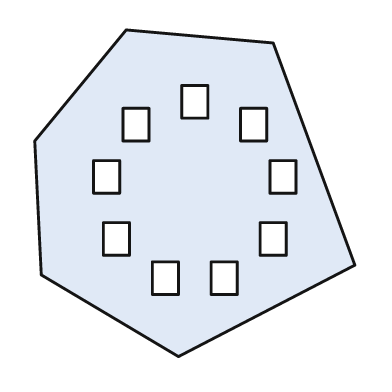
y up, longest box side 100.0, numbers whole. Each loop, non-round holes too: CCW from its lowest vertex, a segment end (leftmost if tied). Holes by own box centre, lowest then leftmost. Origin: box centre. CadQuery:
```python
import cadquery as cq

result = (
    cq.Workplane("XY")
    .moveTo(-5.0, -50.0)
    .lineTo(49.0, -22.0)
    .lineTo(24.0, 46.0)
    .lineTo(-21.0, 50.0)
    .lineTo(-49.0, 16.0)
    .lineTo(-47.0, -25.0)
    .close()
    .moveTo(-13.0, -31.0)
    .lineTo(-5.0, -31.0)
    .lineTo(-5.0, -21.0)
    .lineTo(-13.0, -21.0)
    .close()
    .moveTo(5.0, -31.0)
    .lineTo(13.0, -31.0)
    .lineTo(13.0, -21.0)
    .lineTo(5.0, -21.0)
    .close()
    .moveTo(-28.0, -19.0)
    .lineTo(-20.0, -19.0)
    .lineTo(-20.0, -9.0)
    .lineTo(-28.0, -9.0)
    .close()
    .moveTo(20.0, -19.0)
    .lineTo(28.0, -19.0)
    .lineTo(28.0, -9.0)
    .lineTo(20.0, -9.0)
    .close()
    .moveTo(-31.0, 0.0)
    .lineTo(-23.0, 0.0)
    .lineTo(-23.0, 10.0)
    .lineTo(-31.0, 10.0)
    .close()
    .moveTo(23.0, 0.0)
    .lineTo(31.0, 0.0)
    .lineTo(31.0, 10.0)
    .lineTo(23.0, 10.0)
    .close()
    .moveTo(-22.0, 16.0)
    .lineTo(-14.0, 16.0)
    .lineTo(-14.0, 26.0)
    .lineTo(-22.0, 26.0)
    .close()
    .moveTo(14.0, 16.0)
    .lineTo(22.0, 16.0)
    .lineTo(22.0, 26.0)
    .lineTo(14.0, 26.0)
    .close()
    .moveTo(-4.0, 23.0)
    .lineTo(4.0, 23.0)
    .lineTo(4.0, 33.0)
    .lineTo(-4.0, 33.0)
    .close()
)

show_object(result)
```